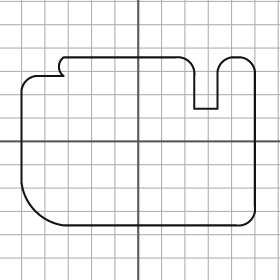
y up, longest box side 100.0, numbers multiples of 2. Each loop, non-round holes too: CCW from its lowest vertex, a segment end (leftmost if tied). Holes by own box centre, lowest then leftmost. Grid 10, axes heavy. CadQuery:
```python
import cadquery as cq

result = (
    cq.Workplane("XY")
    .moveTo(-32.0, -36.0)
    .lineTo(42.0, -36.0)
    .threePointArc((48.0, -34.0), (50.0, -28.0))
    .lineTo(50.0, 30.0)
    .threePointArc((48.0, 34.0), (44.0, 36.0))
    .lineTo(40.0, 36.0)
    .threePointArc((36.0, 34.0), (34.0, 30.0))
    .lineTo(34.0, 14.0)
    .lineTo(24.0, 14.0)
    .lineTo(24.0, 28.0)
    .threePointArc((22.0, 34.0), (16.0, 36.0))
    .lineTo(-32.0, 36.0)
    .threePointArc((-34.0, 32.0), (-32.0, 28.0))
    .lineTo(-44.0, 28.0)
    .threePointArc((-48.0, 26.0), (-50.0, 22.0))
    .lineTo(-50.0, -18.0)
    .threePointArc((-44.0, -30.0), (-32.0, -36.0))
    .close()
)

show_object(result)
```